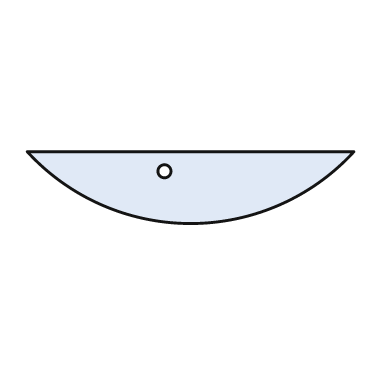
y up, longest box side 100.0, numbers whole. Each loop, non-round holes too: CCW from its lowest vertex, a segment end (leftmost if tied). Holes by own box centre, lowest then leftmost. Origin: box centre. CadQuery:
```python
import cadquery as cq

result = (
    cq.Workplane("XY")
    .moveTo(-50.0, 11.0)
    .threePointArc((0.0, -11.0), (50.0, 11.0))
    .close()
    .moveTo(-8.0, 5.0)
    .circle(2.0)
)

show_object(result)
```